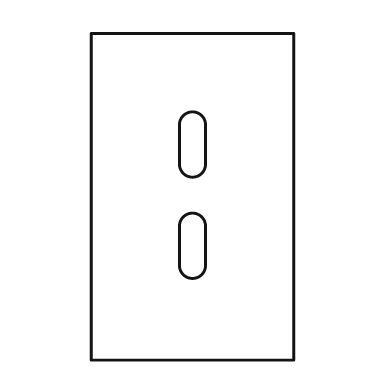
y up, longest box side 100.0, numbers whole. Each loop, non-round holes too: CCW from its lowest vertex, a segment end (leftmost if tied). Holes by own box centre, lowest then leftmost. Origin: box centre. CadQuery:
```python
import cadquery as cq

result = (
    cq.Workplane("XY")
    .moveTo(-31.0, -50.0)
    .lineTo(31.0, -50.0)
    .lineTo(31.0, 50.0)
    .lineTo(-31.0, 50.0)
    .close()
    .moveTo(-4.0, -21.0)
    .threePointArc((0.0, -25.0), (4.0, -21.0))
    .lineTo(4.0, -9.0)
    .threePointArc((0.0, -5.0), (-4.0, -9.0))
    .close()
    .moveTo(-4.0, 10.0)
    .threePointArc((0.0, 6.0), (4.0, 10.0))
    .lineTo(4.0, 22.0)
    .threePointArc((0.0, 26.0), (-4.0, 22.0))
    .close()
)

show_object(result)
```